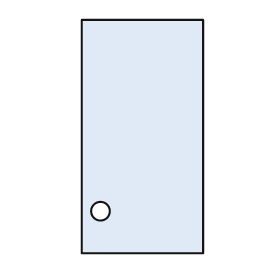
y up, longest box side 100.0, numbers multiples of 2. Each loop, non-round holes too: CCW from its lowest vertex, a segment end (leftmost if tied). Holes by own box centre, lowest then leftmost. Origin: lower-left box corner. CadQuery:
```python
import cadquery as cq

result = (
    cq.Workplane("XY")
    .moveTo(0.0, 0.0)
    .lineTo(52.0, 0.0)
    .lineTo(52.0, 100.0)
    .lineTo(0.0, 100.0)
    .close()
    .moveTo(8.0, 18.0)
    .circle(4.0)
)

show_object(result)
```